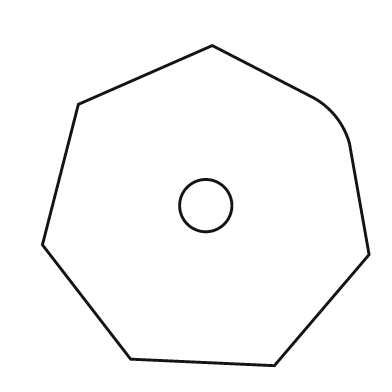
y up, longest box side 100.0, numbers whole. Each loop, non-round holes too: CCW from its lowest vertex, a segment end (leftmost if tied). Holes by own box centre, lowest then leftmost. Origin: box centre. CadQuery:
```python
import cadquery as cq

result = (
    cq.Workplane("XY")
    .moveTo(21.0, -49.0)
    .lineTo(50.0, -15.0)
    .lineTo(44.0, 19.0)
    .threePointArc((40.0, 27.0), (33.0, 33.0))
    .lineTo(2.0, 49.0)
    .lineTo(-39.0, 31.0)
    .lineTo(-50.0, -12.0)
    .lineTo(-23.0, -47.0)
    .close()
    .moveTo(0.0, 0.0)
    .circle(8.0)
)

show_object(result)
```